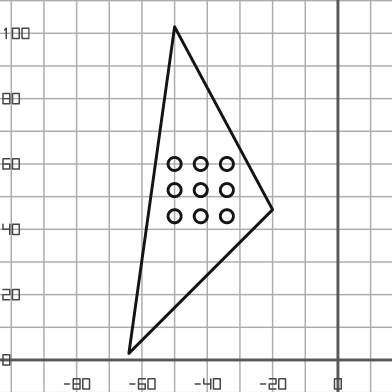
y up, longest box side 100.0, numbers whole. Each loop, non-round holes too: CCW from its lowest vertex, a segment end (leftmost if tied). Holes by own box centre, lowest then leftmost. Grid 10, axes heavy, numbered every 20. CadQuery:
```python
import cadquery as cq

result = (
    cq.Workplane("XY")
    .moveTo(-64.0, 2.0)
    .lineTo(-20.0, 46.0)
    .lineTo(-50.0, 102.0)
    .close()
    .moveTo(-50.0, 44.0)
    .circle(2.0)
    .moveTo(-42.0, 44.0)
    .circle(2.0)
    .moveTo(-34.0, 44.0)
    .circle(2.0)
    .moveTo(-50.0, 52.0)
    .circle(2.0)
    .moveTo(-42.0, 52.0)
    .circle(2.0)
    .moveTo(-34.0, 52.0)
    .circle(2.0)
    .moveTo(-50.0, 60.0)
    .circle(2.0)
    .moveTo(-42.0, 60.0)
    .circle(2.0)
    .moveTo(-34.0, 60.0)
    .circle(2.0)
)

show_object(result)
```